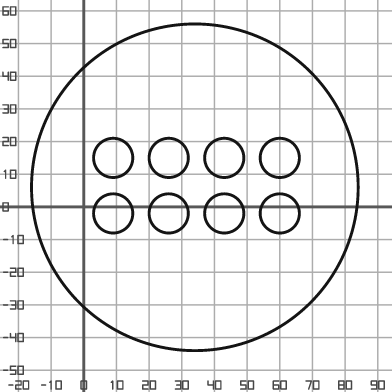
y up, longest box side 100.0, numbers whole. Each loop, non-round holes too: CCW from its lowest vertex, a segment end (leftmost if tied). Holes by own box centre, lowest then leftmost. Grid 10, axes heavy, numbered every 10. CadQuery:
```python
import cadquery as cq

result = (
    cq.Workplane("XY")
    .moveTo(34.0, 6.0)
    .circle(50.0)
    .moveTo(9.0, -2.0)
    .circle(6.0)
    .moveTo(26.0, -2.0)
    .circle(6.0)
    .moveTo(43.0, -2.0)
    .circle(6.0)
    .moveTo(60.0, -2.0)
    .circle(6.0)
    .moveTo(9.0, 15.0)
    .circle(6.0)
    .moveTo(26.0, 15.0)
    .circle(6.0)
    .moveTo(43.0, 15.0)
    .circle(6.0)
    .moveTo(60.0, 15.0)
    .circle(6.0)
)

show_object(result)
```